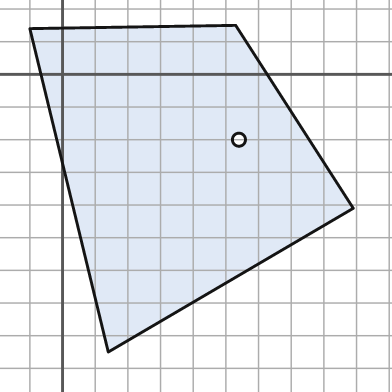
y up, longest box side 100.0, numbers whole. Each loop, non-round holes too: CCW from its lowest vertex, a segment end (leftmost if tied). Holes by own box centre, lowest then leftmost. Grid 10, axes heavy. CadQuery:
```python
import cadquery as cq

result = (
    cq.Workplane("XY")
    .moveTo(14.0, -85.0)
    .lineTo(89.0, -41.0)
    .lineTo(53.0, 15.0)
    .lineTo(-10.0, 14.0)
    .close()
    .moveTo(54.0, -20.0)
    .circle(2.0)
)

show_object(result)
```